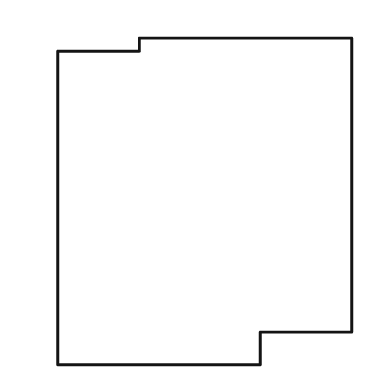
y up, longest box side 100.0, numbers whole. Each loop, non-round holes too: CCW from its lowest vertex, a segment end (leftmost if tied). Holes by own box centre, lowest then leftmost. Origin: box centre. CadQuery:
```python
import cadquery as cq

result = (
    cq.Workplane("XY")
    .moveTo(-45.0, -50.0)
    .lineTo(17.0, -50.0)
    .lineTo(17.0, -40.0)
    .lineTo(45.0, -40.0)
    .lineTo(45.0, 50.0)
    .lineTo(-20.0, 50.0)
    .lineTo(-20.0, 46.0)
    .lineTo(-45.0, 46.0)
    .close()
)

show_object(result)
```